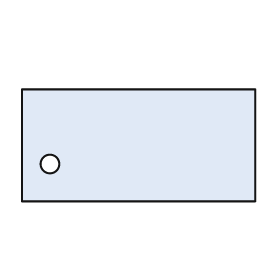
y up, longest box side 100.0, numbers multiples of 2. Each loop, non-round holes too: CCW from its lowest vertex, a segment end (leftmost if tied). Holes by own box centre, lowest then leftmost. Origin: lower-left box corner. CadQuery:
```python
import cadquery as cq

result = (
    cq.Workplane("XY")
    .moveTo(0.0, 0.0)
    .lineTo(100.0, 0.0)
    .lineTo(100.0, 48.0)
    .lineTo(0.0, 48.0)
    .close()
    .moveTo(12.0, 16.0)
    .circle(4.0)
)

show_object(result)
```